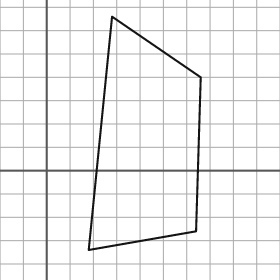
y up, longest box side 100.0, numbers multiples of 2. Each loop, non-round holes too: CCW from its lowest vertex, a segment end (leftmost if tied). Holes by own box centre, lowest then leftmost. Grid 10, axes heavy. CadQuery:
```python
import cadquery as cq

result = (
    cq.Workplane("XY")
    .moveTo(18.0, -34.0)
    .lineTo(64.0, -26.0)
    .lineTo(66.0, 40.0)
    .lineTo(28.0, 66.0)
    .close()
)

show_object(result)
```